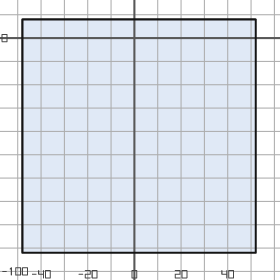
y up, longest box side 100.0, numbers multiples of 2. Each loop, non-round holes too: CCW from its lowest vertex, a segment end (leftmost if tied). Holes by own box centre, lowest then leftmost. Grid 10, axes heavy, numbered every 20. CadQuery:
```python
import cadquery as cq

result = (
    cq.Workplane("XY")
    .moveTo(-48.0, -92.0)
    .lineTo(52.0, -92.0)
    .lineTo(52.0, 8.0)
    .lineTo(-48.0, 8.0)
    .close()
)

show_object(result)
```